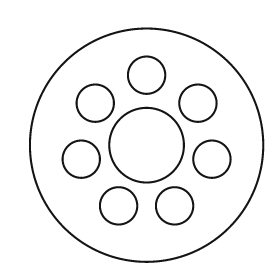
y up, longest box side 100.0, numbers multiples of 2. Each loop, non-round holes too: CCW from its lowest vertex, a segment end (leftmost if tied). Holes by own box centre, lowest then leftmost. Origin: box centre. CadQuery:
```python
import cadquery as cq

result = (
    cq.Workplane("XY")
    .moveTo(0.0, 0.0)
    .circle(50.0)
    .moveTo(-12.0, -26.0)
    .circle(8.0)
    .moveTo(12.0, -26.0)
    .circle(8.0)
    .moveTo(-28.0, -6.0)
    .circle(8.0)
    .moveTo(28.0, -6.0)
    .circle(8.0)
    .moveTo(0.0, 0.0)
    .circle(16.0)
    .moveTo(-22.0, 18.0)
    .circle(8.0)
    .moveTo(22.0, 18.0)
    .circle(8.0)
    .moveTo(0.0, 30.0)
    .circle(8.0)
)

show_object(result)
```